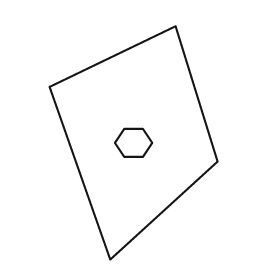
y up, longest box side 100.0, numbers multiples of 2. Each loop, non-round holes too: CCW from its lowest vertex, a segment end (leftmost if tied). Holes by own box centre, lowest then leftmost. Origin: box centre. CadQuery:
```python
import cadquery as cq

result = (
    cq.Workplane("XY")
    .moveTo(-10.0, -50.0)
    .lineTo(36.0, -8.0)
    .lineTo(18.0, 50.0)
    .lineTo(-36.0, 24.0)
    .close()
    .moveTo(-4.0, -6.0)
    .lineTo(4.0, -6.0)
    .lineTo(8.0, 0.0)
    .lineTo(4.0, 6.0)
    .lineTo(-4.0, 6.0)
    .lineTo(-8.0, 0.0)
    .close()
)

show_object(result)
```